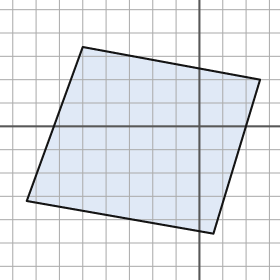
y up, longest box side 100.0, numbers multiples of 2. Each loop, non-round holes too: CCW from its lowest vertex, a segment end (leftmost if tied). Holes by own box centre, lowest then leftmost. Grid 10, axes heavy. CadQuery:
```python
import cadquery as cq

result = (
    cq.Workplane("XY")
    .moveTo(6.0, -46.0)
    .lineTo(26.0, 20.0)
    .lineTo(-50.0, 34.0)
    .lineTo(-74.0, -32.0)
    .close()
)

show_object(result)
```